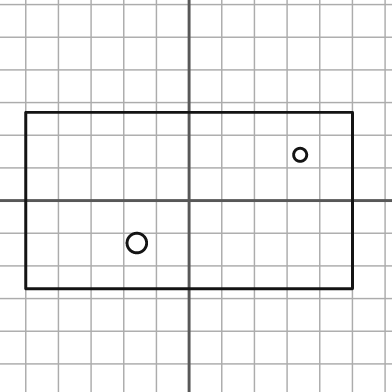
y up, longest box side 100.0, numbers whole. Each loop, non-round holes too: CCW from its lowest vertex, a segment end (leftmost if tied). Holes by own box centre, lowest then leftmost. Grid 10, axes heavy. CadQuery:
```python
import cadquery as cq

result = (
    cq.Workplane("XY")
    .moveTo(-50.0, -27.0)
    .lineTo(50.0, -27.0)
    .lineTo(50.0, 27.0)
    .lineTo(-50.0, 27.0)
    .close()
    .moveTo(-16.0, -13.0)
    .circle(3.0)
    .moveTo(34.0, 14.0)
    .circle(2.0)
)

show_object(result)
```